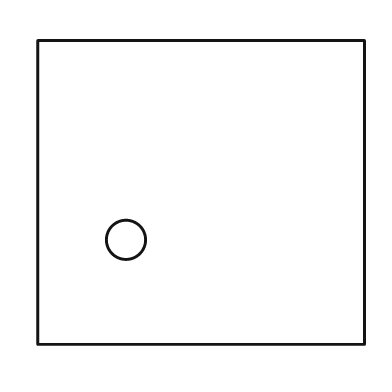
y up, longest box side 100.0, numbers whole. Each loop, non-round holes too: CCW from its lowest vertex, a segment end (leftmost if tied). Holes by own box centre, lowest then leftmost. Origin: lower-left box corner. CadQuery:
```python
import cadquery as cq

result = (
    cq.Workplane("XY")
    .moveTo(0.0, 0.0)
    .lineTo(100.0, 0.0)
    .lineTo(100.0, 93.0)
    .lineTo(0.0, 93.0)
    .close()
    .moveTo(27.0, 32.0)
    .circle(6.0)
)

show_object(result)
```